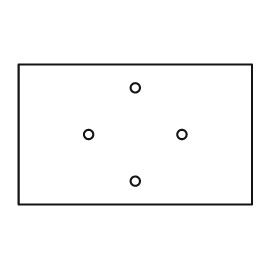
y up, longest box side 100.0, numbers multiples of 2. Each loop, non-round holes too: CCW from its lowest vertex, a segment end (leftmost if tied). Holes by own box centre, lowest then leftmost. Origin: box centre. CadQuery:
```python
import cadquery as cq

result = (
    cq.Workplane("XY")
    .moveTo(-50.0, -30.0)
    .lineTo(50.0, -30.0)
    .lineTo(50.0, 30.0)
    .lineTo(-50.0, 30.0)
    .close()
    .moveTo(0.0, -20.0)
    .circle(2.0)
    .moveTo(-20.0, 0.0)
    .circle(2.0)
    .moveTo(20.0, 0.0)
    .circle(2.0)
    .moveTo(0.0, 20.0)
    .circle(2.0)
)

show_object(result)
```